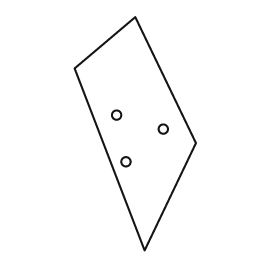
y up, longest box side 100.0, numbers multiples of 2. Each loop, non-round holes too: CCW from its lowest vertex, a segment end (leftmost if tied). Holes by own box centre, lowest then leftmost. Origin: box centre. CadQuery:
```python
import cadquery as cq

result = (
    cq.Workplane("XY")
    .moveTo(4.0, -50.0)
    .lineTo(26.0, -4.0)
    .lineTo(0.0, 50.0)
    .lineTo(-26.0, 28.0)
    .close()
    .moveTo(-4.0, -12.0)
    .circle(2.0)
    .moveTo(12.0, 2.0)
    .circle(2.0)
    .moveTo(-8.0, 8.0)
    .circle(2.0)
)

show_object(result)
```